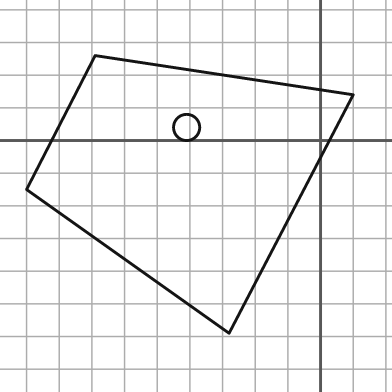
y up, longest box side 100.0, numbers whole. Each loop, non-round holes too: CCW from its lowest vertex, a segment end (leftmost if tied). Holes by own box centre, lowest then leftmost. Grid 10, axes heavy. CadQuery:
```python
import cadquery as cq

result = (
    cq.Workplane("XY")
    .moveTo(-28.0, -59.0)
    .lineTo(10.0, 14.0)
    .lineTo(-69.0, 26.0)
    .lineTo(-90.0, -15.0)
    .close()
    .moveTo(-41.0, 4.0)
    .circle(4.0)
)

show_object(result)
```